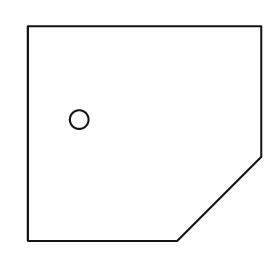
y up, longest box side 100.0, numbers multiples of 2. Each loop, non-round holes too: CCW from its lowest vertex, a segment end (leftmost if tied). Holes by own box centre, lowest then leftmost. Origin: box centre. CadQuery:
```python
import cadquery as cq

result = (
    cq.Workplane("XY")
    .moveTo(-50.0, -46.0)
    .lineTo(14.0, -46.0)
    .lineTo(50.0, -10.0)
    .lineTo(50.0, 46.0)
    .lineTo(-50.0, 46.0)
    .close()
    .moveTo(-28.0, 6.0)
    .circle(4.0)
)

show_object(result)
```